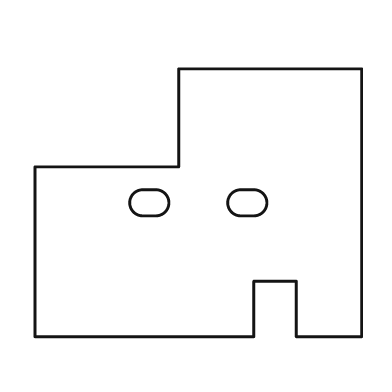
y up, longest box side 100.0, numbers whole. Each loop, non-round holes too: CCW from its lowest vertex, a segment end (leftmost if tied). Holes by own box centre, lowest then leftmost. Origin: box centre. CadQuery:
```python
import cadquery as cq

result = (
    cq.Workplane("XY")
    .moveTo(-50.0, -41.0)
    .lineTo(17.0, -41.0)
    .lineTo(17.0, -24.0)
    .lineTo(30.0, -24.0)
    .lineTo(30.0, -41.0)
    .lineTo(50.0, -41.0)
    .lineTo(50.0, 41.0)
    .lineTo(-6.0, 41.0)
    .lineTo(-6.0, 11.0)
    .lineTo(-50.0, 11.0)
    .close()
    .moveTo(-17.0, -4.0)
    .lineTo(-13.0, -4.0)
    .threePointArc((-9.0, 0.0), (-13.0, 4.0))
    .lineTo(-17.0, 4.0)
    .threePointArc((-21.0, 0.0), (-17.0, -4.0))
    .close()
    .moveTo(13.0, -4.0)
    .lineTo(17.0, -4.0)
    .threePointArc((21.0, 0.0), (17.0, 4.0))
    .lineTo(13.0, 4.0)
    .threePointArc((9.0, 0.0), (13.0, -4.0))
    .close()
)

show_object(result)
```